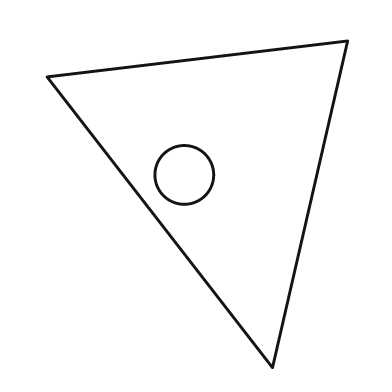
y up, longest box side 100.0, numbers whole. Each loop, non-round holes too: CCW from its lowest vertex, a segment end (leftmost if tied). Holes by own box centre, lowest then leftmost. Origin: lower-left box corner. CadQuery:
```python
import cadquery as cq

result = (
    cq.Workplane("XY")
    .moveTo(69.0, 0.0)
    .lineTo(92.0, 100.0)
    .lineTo(0.0, 89.0)
    .close()
    .moveTo(42.0, 59.0)
    .circle(9.0)
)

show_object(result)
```